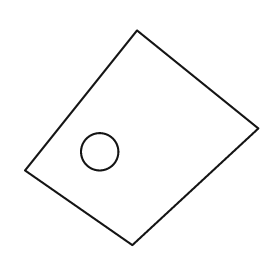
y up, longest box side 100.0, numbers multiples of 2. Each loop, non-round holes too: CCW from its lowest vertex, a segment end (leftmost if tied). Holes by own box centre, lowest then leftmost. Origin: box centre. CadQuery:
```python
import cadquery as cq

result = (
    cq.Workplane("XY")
    .moveTo(-4.0, -46.0)
    .lineTo(50.0, 4.0)
    .lineTo(-2.0, 46.0)
    .lineTo(-50.0, -14.0)
    .close()
    .moveTo(-18.0, -6.0)
    .circle(8.0)
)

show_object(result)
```